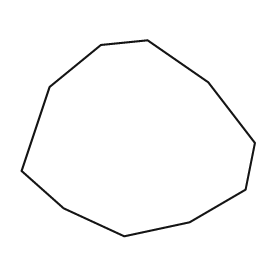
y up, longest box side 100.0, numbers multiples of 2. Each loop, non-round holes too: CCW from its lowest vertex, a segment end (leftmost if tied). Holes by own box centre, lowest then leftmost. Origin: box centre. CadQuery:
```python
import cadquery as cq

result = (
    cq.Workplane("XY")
    .moveTo(-6.0, -42.0)
    .lineTo(22.0, -36.0)
    .lineTo(46.0, -22.0)
    .lineTo(50.0, -2.0)
    .lineTo(30.0, 24.0)
    .lineTo(4.0, 42.0)
    .lineTo(-16.0, 40.0)
    .lineTo(-38.0, 22.0)
    .lineTo(-50.0, -14.0)
    .lineTo(-32.0, -30.0)
    .close()
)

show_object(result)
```